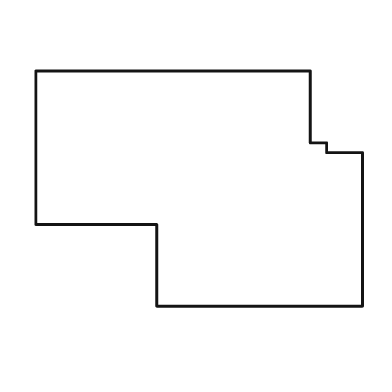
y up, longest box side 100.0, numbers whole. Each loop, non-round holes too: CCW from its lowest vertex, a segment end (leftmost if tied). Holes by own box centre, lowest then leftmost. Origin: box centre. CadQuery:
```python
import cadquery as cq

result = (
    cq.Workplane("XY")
    .moveTo(-13.0, -36.0)
    .lineTo(50.0, -36.0)
    .lineTo(50.0, 11.0)
    .lineTo(39.0, 11.0)
    .lineTo(39.0, 14.0)
    .lineTo(34.0, 14.0)
    .lineTo(34.0, 36.0)
    .lineTo(-50.0, 36.0)
    .lineTo(-50.0, -11.0)
    .lineTo(-13.0, -11.0)
    .close()
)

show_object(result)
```